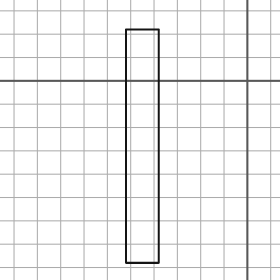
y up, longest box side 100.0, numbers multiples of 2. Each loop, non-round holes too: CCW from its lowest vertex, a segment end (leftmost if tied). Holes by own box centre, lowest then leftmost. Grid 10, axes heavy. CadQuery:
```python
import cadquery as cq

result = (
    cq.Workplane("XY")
    .moveTo(-52.0, -78.0)
    .lineTo(-38.0, -78.0)
    .lineTo(-38.0, 22.0)
    .lineTo(-52.0, 22.0)
    .close()
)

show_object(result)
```